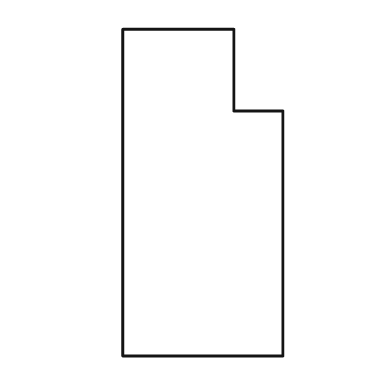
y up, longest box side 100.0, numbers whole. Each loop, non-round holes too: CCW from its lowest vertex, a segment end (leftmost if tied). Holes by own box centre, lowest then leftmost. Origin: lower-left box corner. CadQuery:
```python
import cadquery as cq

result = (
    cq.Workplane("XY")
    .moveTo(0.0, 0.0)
    .lineTo(49.0, 0.0)
    .lineTo(49.0, 75.0)
    .lineTo(34.0, 75.0)
    .lineTo(34.0, 100.0)
    .lineTo(0.0, 100.0)
    .close()
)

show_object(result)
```